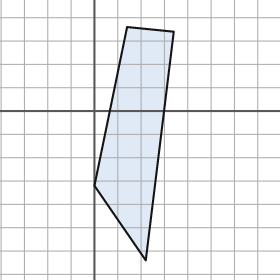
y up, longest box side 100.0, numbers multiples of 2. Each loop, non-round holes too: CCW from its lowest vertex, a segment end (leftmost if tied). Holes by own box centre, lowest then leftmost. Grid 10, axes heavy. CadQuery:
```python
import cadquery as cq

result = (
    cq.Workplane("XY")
    .moveTo(22.0, -64.0)
    .lineTo(34.0, 34.0)
    .lineTo(14.0, 36.0)
    .lineTo(0.0, -32.0)
    .close()
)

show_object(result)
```